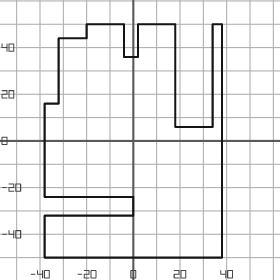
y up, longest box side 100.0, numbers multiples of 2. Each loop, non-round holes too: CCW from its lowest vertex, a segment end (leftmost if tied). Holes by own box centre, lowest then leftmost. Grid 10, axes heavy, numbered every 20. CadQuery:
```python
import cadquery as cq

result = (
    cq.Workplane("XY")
    .moveTo(-38.0, -50.0)
    .lineTo(38.0, -50.0)
    .lineTo(38.0, 50.0)
    .lineTo(34.0, 50.0)
    .lineTo(34.0, 6.0)
    .lineTo(18.0, 6.0)
    .lineTo(18.0, 50.0)
    .lineTo(2.0, 50.0)
    .lineTo(2.0, 36.0)
    .lineTo(-4.0, 36.0)
    .lineTo(-4.0, 50.0)
    .lineTo(-20.0, 50.0)
    .lineTo(-20.0, 44.0)
    .lineTo(-32.0, 44.0)
    .lineTo(-32.0, 16.0)
    .lineTo(-38.0, 16.0)
    .lineTo(-38.0, -24.0)
    .lineTo(0.0, -24.0)
    .lineTo(0.0, -32.0)
    .lineTo(-38.0, -32.0)
    .close()
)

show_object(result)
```